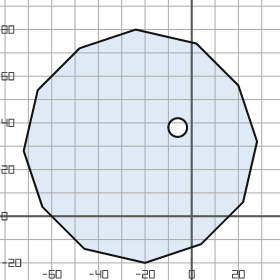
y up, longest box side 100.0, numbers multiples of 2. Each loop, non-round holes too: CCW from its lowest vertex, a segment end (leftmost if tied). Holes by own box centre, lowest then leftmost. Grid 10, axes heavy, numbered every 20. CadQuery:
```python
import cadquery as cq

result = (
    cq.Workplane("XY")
    .moveTo(-20.0, -20.0)
    .lineTo(4.0, -12.0)
    .lineTo(22.0, 6.0)
    .lineTo(28.0, 32.0)
    .lineTo(20.0, 56.0)
    .lineTo(2.0, 74.0)
    .lineTo(-24.0, 80.0)
    .lineTo(-48.0, 72.0)
    .lineTo(-66.0, 54.0)
    .lineTo(-72.0, 28.0)
    .lineTo(-64.0, 4.0)
    .lineTo(-46.0, -14.0)
    .close()
    .moveTo(-6.0, 38.0)
    .circle(4.0)
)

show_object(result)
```